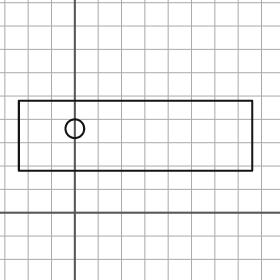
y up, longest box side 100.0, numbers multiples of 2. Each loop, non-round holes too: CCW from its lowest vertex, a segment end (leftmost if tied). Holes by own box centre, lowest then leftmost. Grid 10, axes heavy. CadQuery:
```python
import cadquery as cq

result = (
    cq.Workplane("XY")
    .moveTo(-24.0, 18.0)
    .lineTo(76.0, 18.0)
    .lineTo(76.0, 48.0)
    .lineTo(-24.0, 48.0)
    .close()
    .moveTo(0.0, 36.0)
    .circle(4.0)
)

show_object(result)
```